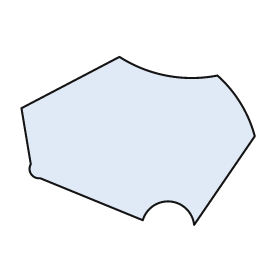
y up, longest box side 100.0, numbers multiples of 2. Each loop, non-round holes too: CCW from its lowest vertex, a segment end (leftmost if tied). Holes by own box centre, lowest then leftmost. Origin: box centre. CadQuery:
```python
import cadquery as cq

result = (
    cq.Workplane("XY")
    .moveTo(24.0, -36.0)
    .lineTo(50.0, 2.0)
    .threePointArc((44.0, 16.0), (34.0, 28.0))
    .threePointArc((12.0, 28.0), (-8.0, 36.0))
    .lineTo(-50.0, 14.0)
    .lineTo(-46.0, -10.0)
    .threePointArc((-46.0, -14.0), (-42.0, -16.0))
    .lineTo(2.0, -34.0)
    .threePointArc((14.0, -26.0), (24.0, -36.0))
    .close()
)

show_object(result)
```